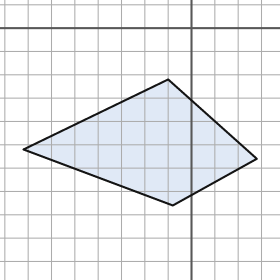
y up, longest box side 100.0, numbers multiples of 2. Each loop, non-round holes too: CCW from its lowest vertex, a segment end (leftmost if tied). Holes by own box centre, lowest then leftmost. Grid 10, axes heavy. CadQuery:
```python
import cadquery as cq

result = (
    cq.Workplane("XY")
    .moveTo(-8.0, -76.0)
    .lineTo(28.0, -56.0)
    .lineTo(-10.0, -22.0)
    .lineTo(-72.0, -52.0)
    .close()
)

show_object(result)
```